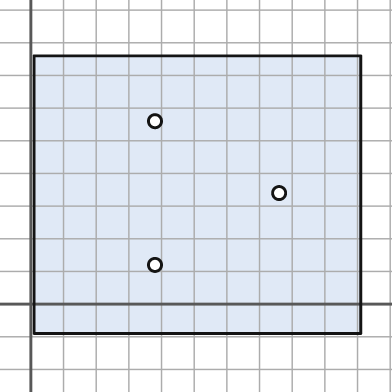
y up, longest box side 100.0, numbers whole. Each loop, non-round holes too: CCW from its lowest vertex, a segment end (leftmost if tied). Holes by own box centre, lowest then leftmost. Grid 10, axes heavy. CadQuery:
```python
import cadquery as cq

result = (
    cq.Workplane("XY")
    .moveTo(1.0, -9.0)
    .lineTo(101.0, -9.0)
    .lineTo(101.0, 76.0)
    .lineTo(1.0, 76.0)
    .close()
    .moveTo(38.0, 12.0)
    .circle(2.0)
    .moveTo(76.0, 34.0)
    .circle(2.0)
    .moveTo(38.0, 56.0)
    .circle(2.0)
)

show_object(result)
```